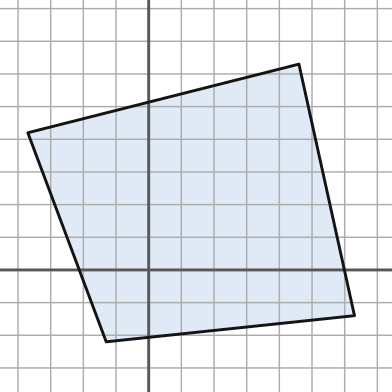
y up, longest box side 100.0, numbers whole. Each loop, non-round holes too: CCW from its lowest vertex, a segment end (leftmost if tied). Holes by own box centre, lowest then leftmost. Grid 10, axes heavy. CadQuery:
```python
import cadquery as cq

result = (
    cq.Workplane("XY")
    .moveTo(-13.0, -22.0)
    .lineTo(63.0, -14.0)
    .lineTo(46.0, 63.0)
    .lineTo(-37.0, 42.0)
    .close()
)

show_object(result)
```